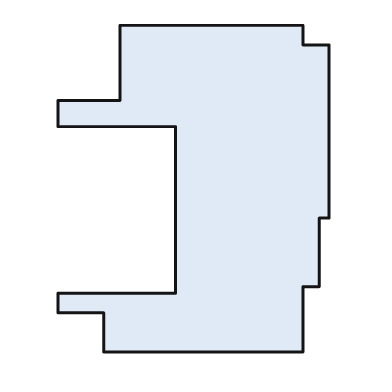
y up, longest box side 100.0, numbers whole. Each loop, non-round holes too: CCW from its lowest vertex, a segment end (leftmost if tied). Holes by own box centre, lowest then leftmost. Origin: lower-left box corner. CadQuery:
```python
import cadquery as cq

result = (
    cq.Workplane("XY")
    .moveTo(14.0, 0.0)
    .lineTo(75.0, 0.0)
    .lineTo(75.0, 20.0)
    .lineTo(80.0, 20.0)
    .lineTo(80.0, 41.0)
    .lineTo(83.0, 41.0)
    .lineTo(83.0, 94.0)
    .lineTo(75.0, 94.0)
    .lineTo(75.0, 100.0)
    .lineTo(19.0, 100.0)
    .lineTo(19.0, 77.0)
    .lineTo(0.0, 77.0)
    .lineTo(0.0, 69.0)
    .lineTo(36.0, 69.0)
    .lineTo(36.0, 18.0)
    .lineTo(0.0, 18.0)
    .lineTo(0.0, 12.0)
    .lineTo(14.0, 12.0)
    .close()
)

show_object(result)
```